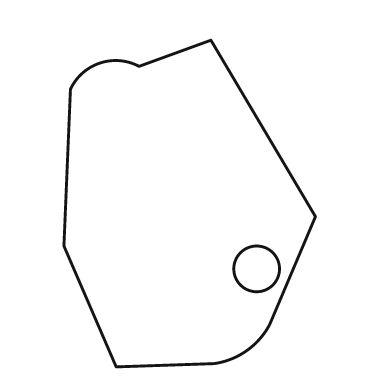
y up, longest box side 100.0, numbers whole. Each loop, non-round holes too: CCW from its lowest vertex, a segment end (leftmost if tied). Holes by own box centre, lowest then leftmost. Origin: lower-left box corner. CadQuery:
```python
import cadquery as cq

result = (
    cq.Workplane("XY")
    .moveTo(16.0, 0.0)
    .lineTo(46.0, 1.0)
    .threePointArc((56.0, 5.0), (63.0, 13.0))
    .lineTo(77.0, 46.0)
    .lineTo(45.0, 100.0)
    .lineTo(23.0, 92.0)
    .threePointArc((11.0, 93.0), (2.0, 85.0))
    .lineTo(0.0, 37.0)
    .close()
    .moveTo(59.0, 30.0)
    .circle(7.0)
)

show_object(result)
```